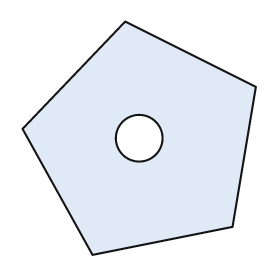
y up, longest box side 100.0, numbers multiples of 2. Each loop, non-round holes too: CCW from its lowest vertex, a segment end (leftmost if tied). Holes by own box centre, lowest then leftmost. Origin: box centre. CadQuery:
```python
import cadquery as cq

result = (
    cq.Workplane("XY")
    .moveTo(-20.0, -50.0)
    .lineTo(40.0, -38.0)
    .lineTo(50.0, 22.0)
    .lineTo(-6.0, 50.0)
    .lineTo(-50.0, 4.0)
    .close()
    .moveTo(0.0, 0.0)
    .circle(10.0)
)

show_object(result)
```